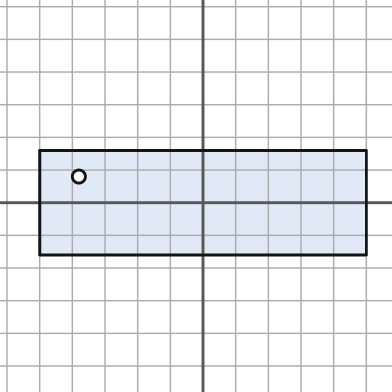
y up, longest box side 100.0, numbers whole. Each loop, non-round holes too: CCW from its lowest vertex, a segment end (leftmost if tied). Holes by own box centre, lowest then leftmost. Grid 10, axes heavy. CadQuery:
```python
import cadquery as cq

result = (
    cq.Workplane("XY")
    .moveTo(-50.0, -16.0)
    .lineTo(50.0, -16.0)
    .lineTo(50.0, 16.0)
    .lineTo(-50.0, 16.0)
    .close()
    .moveTo(-38.0, 8.0)
    .circle(2.0)
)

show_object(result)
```